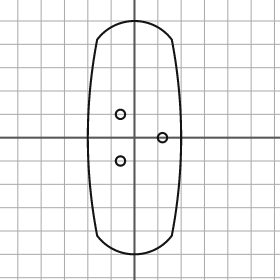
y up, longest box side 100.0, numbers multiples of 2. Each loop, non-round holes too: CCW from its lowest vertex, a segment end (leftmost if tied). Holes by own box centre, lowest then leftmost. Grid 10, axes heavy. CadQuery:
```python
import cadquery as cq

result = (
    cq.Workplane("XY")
    .moveTo(-16.0, -42.0)
    .threePointArc((0.0, -50.0), (16.0, -42.0))
    .threePointArc((20.0, 0.0), (16.0, 42.0))
    .threePointArc((0.0, 50.0), (-16.0, 42.0))
    .threePointArc((-20.0, 0.0), (-16.0, -42.0))
    .close()
    .moveTo(-6.0, -10.0)
    .circle(2.0)
    .moveTo(12.0, 0.0)
    .circle(2.0)
    .moveTo(-6.0, 10.0)
    .circle(2.0)
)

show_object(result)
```